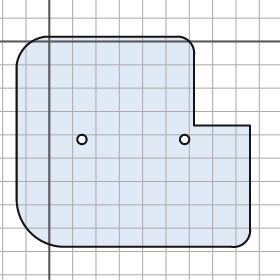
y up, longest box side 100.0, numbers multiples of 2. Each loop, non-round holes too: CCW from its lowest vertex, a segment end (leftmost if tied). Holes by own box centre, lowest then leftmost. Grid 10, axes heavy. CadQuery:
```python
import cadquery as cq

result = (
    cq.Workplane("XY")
    .moveTo(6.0, -88.0)
    .lineTo(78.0, -88.0)
    .threePointArc((84.0, -86.0), (86.0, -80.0))
    .lineTo(86.0, -36.0)
    .lineTo(62.0, -36.0)
    .lineTo(62.0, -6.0)
    .threePointArc((60.0, 0.0), (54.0, 2.0))
    .lineTo(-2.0, 2.0)
    .threePointArc((-10.0, -2.0), (-14.0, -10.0))
    .lineTo(-14.0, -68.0)
    .threePointArc((-8.0, -82.0), (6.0, -88.0))
    .close()
    .moveTo(14.0, -42.0)
    .circle(2.0)
    .moveTo(58.0, -42.0)
    .circle(2.0)
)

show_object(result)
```